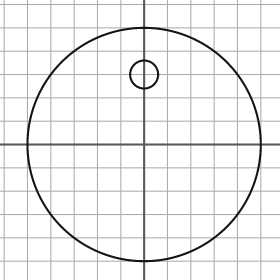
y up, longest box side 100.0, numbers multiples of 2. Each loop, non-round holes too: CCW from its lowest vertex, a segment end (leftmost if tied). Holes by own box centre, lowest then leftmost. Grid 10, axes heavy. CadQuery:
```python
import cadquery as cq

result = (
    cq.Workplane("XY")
    .moveTo(0.0, 0.0)
    .circle(50.0)
    .moveTo(0.0, 30.0)
    .circle(6.0)
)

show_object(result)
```